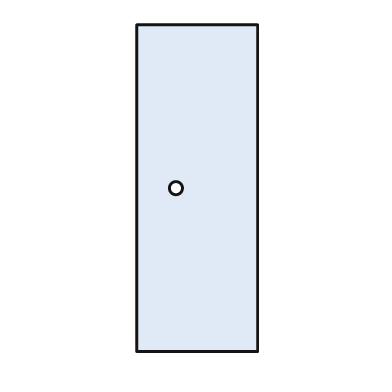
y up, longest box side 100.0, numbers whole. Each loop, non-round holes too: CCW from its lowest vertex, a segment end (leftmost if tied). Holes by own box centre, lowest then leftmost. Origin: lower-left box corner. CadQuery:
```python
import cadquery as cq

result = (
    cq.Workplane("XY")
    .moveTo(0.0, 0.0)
    .lineTo(37.0, 0.0)
    .lineTo(37.0, 100.0)
    .lineTo(0.0, 100.0)
    .close()
    .moveTo(12.0, 50.0)
    .circle(2.0)
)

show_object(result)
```